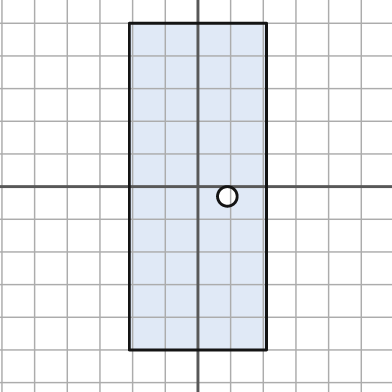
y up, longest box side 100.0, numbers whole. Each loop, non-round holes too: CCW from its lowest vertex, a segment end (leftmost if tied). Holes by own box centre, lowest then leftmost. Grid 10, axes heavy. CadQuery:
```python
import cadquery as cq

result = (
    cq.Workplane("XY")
    .moveTo(-21.0, -50.0)
    .lineTo(21.0, -50.0)
    .lineTo(21.0, 50.0)
    .lineTo(-21.0, 50.0)
    .close()
    .moveTo(9.0, -3.0)
    .circle(3.0)
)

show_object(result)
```